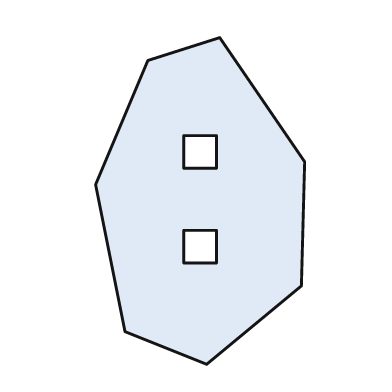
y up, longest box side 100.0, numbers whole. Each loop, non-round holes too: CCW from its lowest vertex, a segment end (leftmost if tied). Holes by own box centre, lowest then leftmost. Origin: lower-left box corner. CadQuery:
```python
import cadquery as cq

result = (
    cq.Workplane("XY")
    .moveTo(34.0, 0.0)
    .lineTo(63.0, 24.0)
    .lineTo(64.0, 62.0)
    .lineTo(38.0, 100.0)
    .lineTo(16.0, 93.0)
    .lineTo(0.0, 55.0)
    .lineTo(9.0, 10.0)
    .close()
    .moveTo(27.0, 31.0)
    .lineTo(37.0, 31.0)
    .lineTo(37.0, 41.0)
    .lineTo(27.0, 41.0)
    .close()
    .moveTo(27.0, 60.0)
    .lineTo(37.0, 60.0)
    .lineTo(37.0, 70.0)
    .lineTo(27.0, 70.0)
    .close()
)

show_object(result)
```